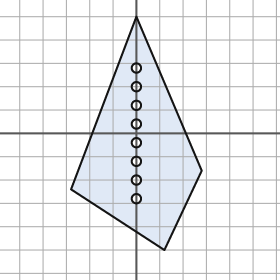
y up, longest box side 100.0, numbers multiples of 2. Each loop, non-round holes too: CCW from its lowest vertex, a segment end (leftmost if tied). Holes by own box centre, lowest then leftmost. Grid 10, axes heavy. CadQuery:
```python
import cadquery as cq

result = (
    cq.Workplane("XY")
    .moveTo(12.0, -50.0)
    .lineTo(28.0, -16.0)
    .lineTo(0.0, 50.0)
    .lineTo(-28.0, -24.0)
    .close()
    .moveTo(0.0, -28.0)
    .circle(2.0)
    .moveTo(0.0, -20.0)
    .circle(2.0)
    .moveTo(0.0, -12.0)
    .circle(2.0)
    .moveTo(0.0, -4.0)
    .circle(2.0)
    .moveTo(0.0, 4.0)
    .circle(2.0)
    .moveTo(0.0, 12.0)
    .circle(2.0)
    .moveTo(0.0, 20.0)
    .circle(2.0)
    .moveTo(0.0, 28.0)
    .circle(2.0)
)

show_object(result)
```